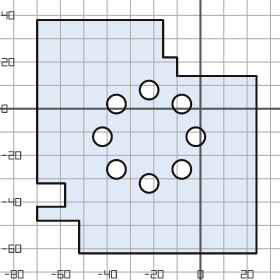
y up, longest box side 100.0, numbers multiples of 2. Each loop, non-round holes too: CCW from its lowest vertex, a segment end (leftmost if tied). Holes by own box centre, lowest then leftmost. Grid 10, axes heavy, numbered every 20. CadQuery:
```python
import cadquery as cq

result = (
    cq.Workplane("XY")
    .moveTo(-52.0, -62.0)
    .lineTo(24.0, -62.0)
    .lineTo(24.0, 14.0)
    .lineTo(-10.0, 14.0)
    .lineTo(-10.0, 22.0)
    .lineTo(-16.0, 22.0)
    .lineTo(-16.0, 38.0)
    .lineTo(-70.0, 38.0)
    .lineTo(-70.0, -32.0)
    .lineTo(-58.0, -32.0)
    .lineTo(-58.0, -42.0)
    .lineTo(-70.0, -42.0)
    .lineTo(-70.0, -48.0)
    .lineTo(-52.0, -48.0)
    .close()
    .moveTo(-22.0, -32.0)
    .circle(4.0)
    .moveTo(-36.0, -26.0)
    .circle(4.0)
    .moveTo(-8.0, -26.0)
    .circle(4.0)
    .moveTo(-42.0, -12.0)
    .circle(4.0)
    .moveTo(-2.0, -12.0)
    .circle(4.0)
    .moveTo(-36.0, 2.0)
    .circle(4.0)
    .moveTo(-8.0, 2.0)
    .circle(4.0)
    .moveTo(-22.0, 8.0)
    .circle(4.0)
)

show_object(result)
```